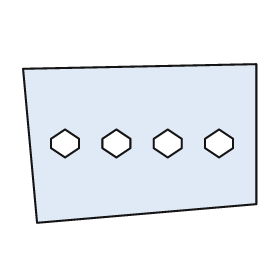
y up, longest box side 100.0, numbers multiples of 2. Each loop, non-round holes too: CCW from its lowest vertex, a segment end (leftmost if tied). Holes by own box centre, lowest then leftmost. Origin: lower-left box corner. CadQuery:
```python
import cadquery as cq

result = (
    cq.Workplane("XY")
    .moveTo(6.0, 0.0)
    .lineTo(100.0, 8.0)
    .lineTo(100.0, 68.0)
    .lineTo(0.0, 66.0)
    .close()
    .moveTo(18.0, 28.0)
    .lineTo(24.0, 32.0)
    .lineTo(24.0, 36.0)
    .lineTo(18.0, 40.0)
    .lineTo(12.0, 36.0)
    .lineTo(12.0, 32.0)
    .close()
    .moveTo(40.0, 28.0)
    .lineTo(46.0, 32.0)
    .lineTo(46.0, 36.0)
    .lineTo(40.0, 40.0)
    .lineTo(34.0, 36.0)
    .lineTo(34.0, 32.0)
    .close()
    .moveTo(62.0, 28.0)
    .lineTo(68.0, 32.0)
    .lineTo(68.0, 36.0)
    .lineTo(62.0, 40.0)
    .lineTo(56.0, 36.0)
    .lineTo(56.0, 32.0)
    .close()
    .moveTo(84.0, 28.0)
    .lineTo(90.0, 32.0)
    .lineTo(90.0, 36.0)
    .lineTo(84.0, 40.0)
    .lineTo(78.0, 36.0)
    .lineTo(78.0, 32.0)
    .close()
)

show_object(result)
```